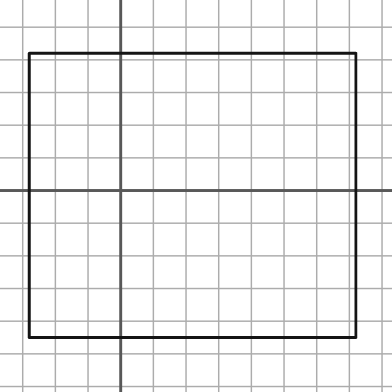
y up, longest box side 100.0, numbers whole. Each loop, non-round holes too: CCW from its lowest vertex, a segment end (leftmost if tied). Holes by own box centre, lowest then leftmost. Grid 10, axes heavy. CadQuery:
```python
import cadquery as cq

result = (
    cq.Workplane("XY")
    .moveTo(-28.0, -45.0)
    .lineTo(72.0, -45.0)
    .lineTo(72.0, 42.0)
    .lineTo(-28.0, 42.0)
    .close()
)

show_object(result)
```